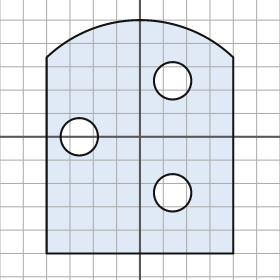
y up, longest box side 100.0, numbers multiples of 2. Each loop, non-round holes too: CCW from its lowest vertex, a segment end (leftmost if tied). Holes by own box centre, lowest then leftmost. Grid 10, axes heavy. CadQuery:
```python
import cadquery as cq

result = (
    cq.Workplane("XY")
    .moveTo(-40.0, -50.0)
    .lineTo(40.0, -50.0)
    .lineTo(40.0, 34.0)
    .threePointArc((0.0, 50.0), (-40.0, 34.0))
    .close()
    .moveTo(14.0, -24.0)
    .circle(8.0)
    .moveTo(-26.0, 0.0)
    .circle(8.0)
    .moveTo(14.0, 24.0)
    .circle(8.0)
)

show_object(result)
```